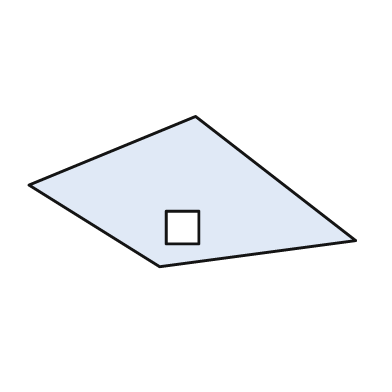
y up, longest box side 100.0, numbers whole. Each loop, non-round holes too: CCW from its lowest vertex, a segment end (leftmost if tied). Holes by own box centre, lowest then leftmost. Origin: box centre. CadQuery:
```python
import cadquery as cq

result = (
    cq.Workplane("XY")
    .moveTo(-10.0, -23.0)
    .lineTo(50.0, -15.0)
    .lineTo(1.0, 23.0)
    .lineTo(-50.0, 2.0)
    .close()
    .moveTo(-8.0, -16.0)
    .lineTo(2.0, -16.0)
    .lineTo(2.0, -6.0)
    .lineTo(-8.0, -6.0)
    .close()
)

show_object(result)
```